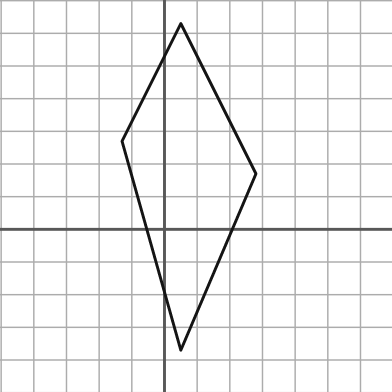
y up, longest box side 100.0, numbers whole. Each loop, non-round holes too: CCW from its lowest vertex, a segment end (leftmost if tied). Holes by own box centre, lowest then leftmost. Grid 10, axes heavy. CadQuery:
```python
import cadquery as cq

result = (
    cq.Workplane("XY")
    .moveTo(5.0, -37.0)
    .lineTo(28.0, 17.0)
    .lineTo(5.0, 63.0)
    .lineTo(-13.0, 27.0)
    .close()
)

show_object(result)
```